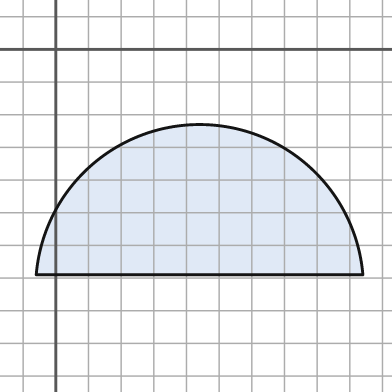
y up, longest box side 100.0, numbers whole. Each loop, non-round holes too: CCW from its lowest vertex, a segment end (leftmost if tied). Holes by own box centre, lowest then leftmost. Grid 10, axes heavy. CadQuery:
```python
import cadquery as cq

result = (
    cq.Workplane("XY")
    .moveTo(-6.0, -69.0)
    .lineTo(94.0, -69.0)
    .threePointArc((44.0, -23.0), (-6.0, -69.0))
    .close()
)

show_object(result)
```